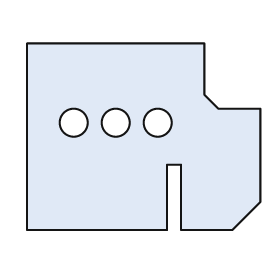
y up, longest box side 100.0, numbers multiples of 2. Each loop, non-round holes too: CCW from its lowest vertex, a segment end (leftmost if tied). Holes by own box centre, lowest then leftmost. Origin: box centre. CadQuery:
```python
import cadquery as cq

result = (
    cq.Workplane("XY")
    .moveTo(-50.0, -40.0)
    .lineTo(10.0, -40.0)
    .lineTo(10.0, -12.0)
    .lineTo(16.0, -12.0)
    .lineTo(16.0, -40.0)
    .lineTo(38.0, -40.0)
    .lineTo(50.0, -28.0)
    .lineTo(50.0, 12.0)
    .lineTo(32.0, 12.0)
    .lineTo(26.0, 18.0)
    .lineTo(26.0, 40.0)
    .lineTo(-50.0, 40.0)
    .close()
    .moveTo(-30.0, 6.0)
    .circle(6.0)
    .moveTo(-12.0, 6.0)
    .circle(6.0)
    .moveTo(6.0, 6.0)
    .circle(6.0)
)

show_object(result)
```